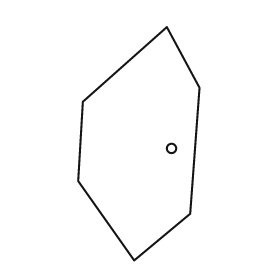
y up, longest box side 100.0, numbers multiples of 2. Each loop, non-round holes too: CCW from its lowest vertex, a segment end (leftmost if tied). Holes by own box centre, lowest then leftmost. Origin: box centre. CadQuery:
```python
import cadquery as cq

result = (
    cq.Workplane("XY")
    .moveTo(-2.0, -50.0)
    .lineTo(22.0, -30.0)
    .lineTo(26.0, 24.0)
    .lineTo(12.0, 50.0)
    .lineTo(-24.0, 18.0)
    .lineTo(-26.0, -16.0)
    .close()
    .moveTo(14.0, -2.0)
    .circle(2.0)
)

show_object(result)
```